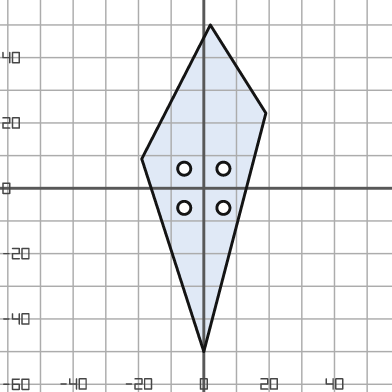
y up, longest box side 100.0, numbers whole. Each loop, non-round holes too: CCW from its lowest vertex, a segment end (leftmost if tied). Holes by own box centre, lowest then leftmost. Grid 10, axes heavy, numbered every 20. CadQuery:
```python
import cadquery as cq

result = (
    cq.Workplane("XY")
    .moveTo(0.0, -50.0)
    .lineTo(19.0, 23.0)
    .lineTo(2.0, 50.0)
    .lineTo(-19.0, 9.0)
    .close()
    .moveTo(-6.0, -6.0)
    .circle(2.0)
    .moveTo(6.0, -6.0)
    .circle(2.0)
    .moveTo(-6.0, 6.0)
    .circle(2.0)
    .moveTo(6.0, 6.0)
    .circle(2.0)
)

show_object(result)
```